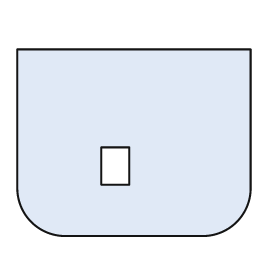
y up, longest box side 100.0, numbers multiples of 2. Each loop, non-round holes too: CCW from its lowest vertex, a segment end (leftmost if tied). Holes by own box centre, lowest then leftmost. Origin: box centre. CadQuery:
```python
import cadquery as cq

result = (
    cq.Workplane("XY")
    .moveTo(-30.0, -40.0)
    .lineTo(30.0, -40.0)
    .threePointArc((44.0, -34.0), (50.0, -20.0))
    .lineTo(50.0, 40.0)
    .lineTo(-50.0, 40.0)
    .lineTo(-50.0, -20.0)
    .threePointArc((-44.0, -34.0), (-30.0, -40.0))
    .close()
    .moveTo(-14.0, -18.0)
    .lineTo(-2.0, -18.0)
    .lineTo(-2.0, -2.0)
    .lineTo(-14.0, -2.0)
    .close()
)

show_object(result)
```